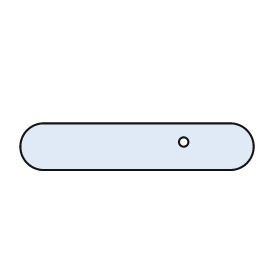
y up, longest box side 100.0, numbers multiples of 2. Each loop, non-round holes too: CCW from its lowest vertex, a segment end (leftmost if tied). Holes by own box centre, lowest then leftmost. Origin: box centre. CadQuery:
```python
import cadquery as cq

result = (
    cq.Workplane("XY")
    .moveTo(-40.0, -10.0)
    .lineTo(40.0, -10.0)
    .threePointArc((50.0, 0.0), (40.0, 10.0))
    .lineTo(-40.0, 10.0)
    .threePointArc((-50.0, 0.0), (-40.0, -10.0))
    .close()
    .moveTo(20.0, 2.0)
    .circle(2.0)
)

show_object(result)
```